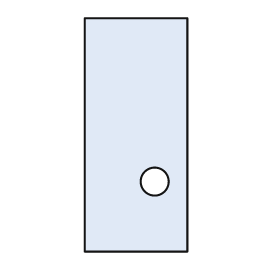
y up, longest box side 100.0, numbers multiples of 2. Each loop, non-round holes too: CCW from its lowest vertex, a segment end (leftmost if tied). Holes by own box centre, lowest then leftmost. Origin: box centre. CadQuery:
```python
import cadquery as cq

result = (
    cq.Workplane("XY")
    .moveTo(-22.0, -50.0)
    .lineTo(22.0, -50.0)
    .lineTo(22.0, 50.0)
    .lineTo(-22.0, 50.0)
    .close()
    .moveTo(8.0, -20.0)
    .circle(6.0)
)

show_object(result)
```